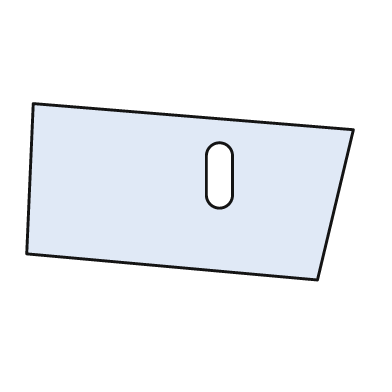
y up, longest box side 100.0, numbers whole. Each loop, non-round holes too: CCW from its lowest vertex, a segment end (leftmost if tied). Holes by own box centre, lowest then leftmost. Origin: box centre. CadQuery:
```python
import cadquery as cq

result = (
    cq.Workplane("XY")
    .moveTo(39.0, -27.0)
    .lineTo(50.0, 19.0)
    .lineTo(-48.0, 27.0)
    .lineTo(-50.0, -19.0)
    .close()
    .moveTo(5.0, -1.0)
    .threePointArc((9.0, -5.0), (13.0, -1.0))
    .lineTo(13.0, 11.0)
    .threePointArc((9.0, 15.0), (5.0, 11.0))
    .close()
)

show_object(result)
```